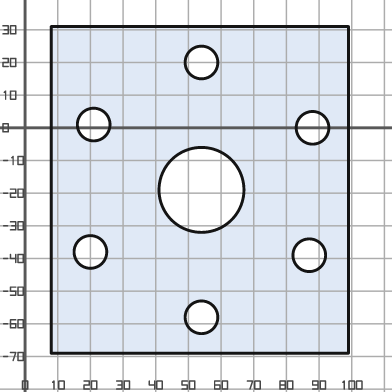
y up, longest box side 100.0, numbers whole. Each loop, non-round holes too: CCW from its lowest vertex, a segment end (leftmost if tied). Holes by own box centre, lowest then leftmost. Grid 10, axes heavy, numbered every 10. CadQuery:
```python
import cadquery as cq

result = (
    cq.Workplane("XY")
    .moveTo(8.0, -69.0)
    .lineTo(99.0, -69.0)
    .lineTo(99.0, 31.0)
    .lineTo(8.0, 31.0)
    .close()
    .moveTo(54.0, -58.0)
    .circle(5.0)
    .moveTo(87.0, -39.0)
    .circle(5.0)
    .moveTo(20.0, -38.0)
    .circle(5.0)
    .moveTo(54.0, -19.0)
    .circle(13.0)
    .moveTo(88.0, 0.0)
    .circle(5.0)
    .moveTo(21.0, 1.0)
    .circle(5.0)
    .moveTo(54.0, 20.0)
    .circle(5.0)
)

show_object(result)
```